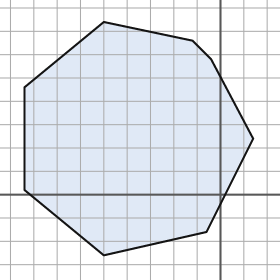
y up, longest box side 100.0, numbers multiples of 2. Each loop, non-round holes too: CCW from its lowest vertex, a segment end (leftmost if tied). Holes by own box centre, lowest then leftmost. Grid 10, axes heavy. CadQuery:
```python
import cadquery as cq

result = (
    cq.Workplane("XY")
    .moveTo(-50.0, -26.0)
    .lineTo(-6.0, -16.0)
    .lineTo(14.0, 24.0)
    .lineTo(-4.0, 58.0)
    .lineTo(-12.0, 66.0)
    .lineTo(-50.0, 74.0)
    .lineTo(-84.0, 46.0)
    .lineTo(-84.0, 2.0)
    .close()
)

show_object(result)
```